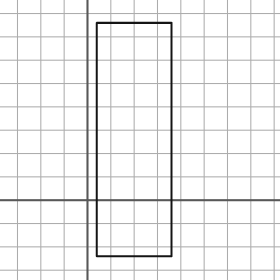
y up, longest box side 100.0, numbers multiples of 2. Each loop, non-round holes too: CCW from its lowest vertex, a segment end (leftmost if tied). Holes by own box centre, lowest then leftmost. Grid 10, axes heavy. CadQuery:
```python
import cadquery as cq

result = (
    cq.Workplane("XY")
    .moveTo(4.0, -24.0)
    .lineTo(36.0, -24.0)
    .lineTo(36.0, 76.0)
    .lineTo(4.0, 76.0)
    .close()
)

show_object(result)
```